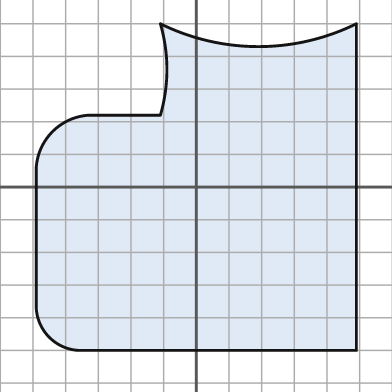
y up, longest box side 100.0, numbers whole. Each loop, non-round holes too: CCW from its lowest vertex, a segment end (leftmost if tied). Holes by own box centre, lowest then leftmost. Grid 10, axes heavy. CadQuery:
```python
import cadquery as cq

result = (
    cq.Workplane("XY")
    .moveTo(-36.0, -50.0)
    .lineTo(49.0, -50.0)
    .lineTo(49.0, 50.0)
    .threePointArc((19.0, 43.0), (-11.0, 50.0))
    .threePointArc((-9.0, 36.0), (-11.0, 22.0))
    .lineTo(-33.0, 22.0)
    .threePointArc((-44.0, 17.0), (-49.0, 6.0))
    .lineTo(-49.0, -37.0)
    .threePointArc((-45.0, -46.0), (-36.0, -50.0))
    .close()
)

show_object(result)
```